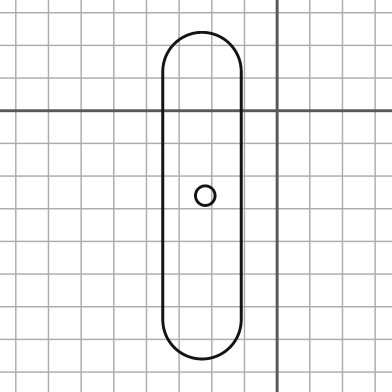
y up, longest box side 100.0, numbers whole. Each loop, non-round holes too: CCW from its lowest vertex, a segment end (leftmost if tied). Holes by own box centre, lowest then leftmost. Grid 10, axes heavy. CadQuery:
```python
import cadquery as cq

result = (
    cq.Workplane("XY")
    .moveTo(-35.0, -64.0)
    .threePointArc((-23.0, -76.0), (-11.0, -64.0))
    .lineTo(-11.0, 12.0)
    .threePointArc((-23.0, 24.0), (-35.0, 12.0))
    .close()
    .moveTo(-22.0, -26.0)
    .circle(3.0)
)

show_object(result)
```